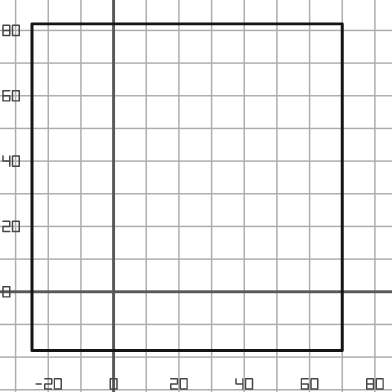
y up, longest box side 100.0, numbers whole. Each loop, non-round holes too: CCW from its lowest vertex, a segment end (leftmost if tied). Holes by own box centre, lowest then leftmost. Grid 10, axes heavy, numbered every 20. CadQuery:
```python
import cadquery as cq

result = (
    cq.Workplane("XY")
    .moveTo(-25.0, -18.0)
    .lineTo(70.0, -18.0)
    .lineTo(70.0, 82.0)
    .lineTo(-25.0, 82.0)
    .close()
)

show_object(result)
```